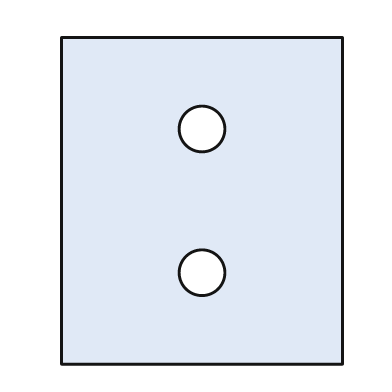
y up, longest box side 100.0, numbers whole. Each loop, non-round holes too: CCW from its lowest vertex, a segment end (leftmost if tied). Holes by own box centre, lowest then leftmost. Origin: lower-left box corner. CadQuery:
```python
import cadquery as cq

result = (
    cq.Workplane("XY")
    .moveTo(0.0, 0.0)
    .lineTo(86.0, 0.0)
    .lineTo(86.0, 100.0)
    .lineTo(0.0, 100.0)
    .close()
    .moveTo(43.0, 28.0)
    .circle(7.0)
    .moveTo(43.0, 72.0)
    .circle(7.0)
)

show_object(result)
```